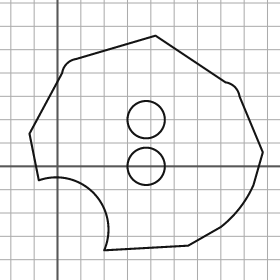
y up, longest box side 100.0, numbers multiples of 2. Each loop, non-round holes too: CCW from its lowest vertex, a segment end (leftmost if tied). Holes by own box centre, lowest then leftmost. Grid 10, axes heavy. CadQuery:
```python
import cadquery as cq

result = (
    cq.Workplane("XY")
    .moveTo(20.0, -36.0)
    .lineTo(56.0, -34.0)
    .lineTo(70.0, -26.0)
    .threePointArc((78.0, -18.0), (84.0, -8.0))
    .lineTo(88.0, 6.0)
    .lineTo(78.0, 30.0)
    .threePointArc((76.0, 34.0), (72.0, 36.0))
    .lineTo(42.0, 56.0)
    .lineTo(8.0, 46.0)
    .threePointArc((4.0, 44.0), (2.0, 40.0))
    .lineTo(-12.0, 14.0)
    .lineTo(-8.0, -6.0)
    .threePointArc((16.0, -12.0), (20.0, -36.0))
    .close()
    .moveTo(38.0, 0.0)
    .circle(8.0)
    .moveTo(38.0, 20.0)
    .circle(8.0)
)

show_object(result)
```